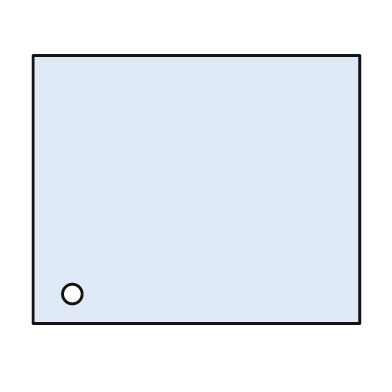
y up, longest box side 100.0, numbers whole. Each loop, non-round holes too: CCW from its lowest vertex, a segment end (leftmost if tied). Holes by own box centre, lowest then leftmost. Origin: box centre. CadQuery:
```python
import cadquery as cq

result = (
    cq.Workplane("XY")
    .moveTo(-50.0, -41.0)
    .lineTo(50.0, -41.0)
    .lineTo(50.0, 41.0)
    .lineTo(-50.0, 41.0)
    .close()
    .moveTo(-38.0, -32.0)
    .circle(3.0)
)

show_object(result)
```